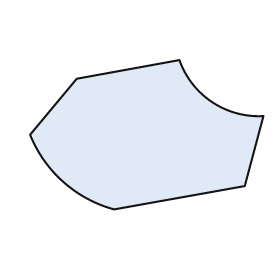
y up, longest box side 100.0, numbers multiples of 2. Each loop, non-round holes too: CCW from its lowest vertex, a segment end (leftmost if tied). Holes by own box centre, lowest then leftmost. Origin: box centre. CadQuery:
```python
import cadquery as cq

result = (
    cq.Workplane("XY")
    .moveTo(-14.0, -32.0)
    .lineTo(42.0, -22.0)
    .lineTo(50.0, 8.0)
    .threePointArc((28.0, 14.0), (14.0, 32.0))
    .lineTo(-30.0, 24.0)
    .lineTo(-50.0, 0.0)
    .threePointArc((-36.0, -20.0), (-14.0, -32.0))
    .close()
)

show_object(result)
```